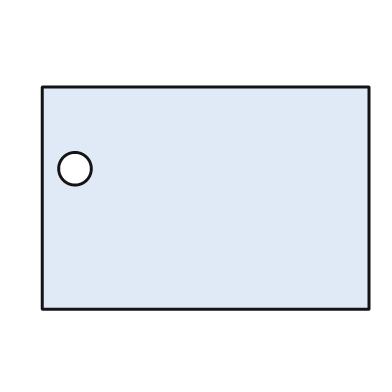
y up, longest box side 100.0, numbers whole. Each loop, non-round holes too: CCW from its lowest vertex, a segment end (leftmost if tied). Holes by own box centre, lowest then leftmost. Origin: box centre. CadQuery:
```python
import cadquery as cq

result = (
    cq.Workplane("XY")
    .moveTo(-50.0, -34.0)
    .lineTo(50.0, -34.0)
    .lineTo(50.0, 34.0)
    .lineTo(-50.0, 34.0)
    .close()
    .moveTo(-40.0, 9.0)
    .circle(5.0)
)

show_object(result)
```